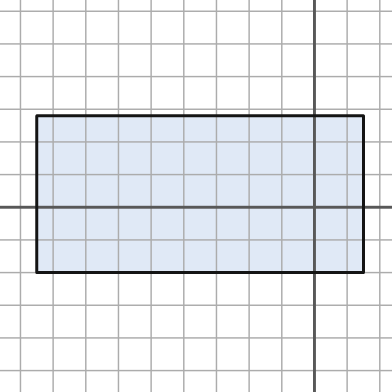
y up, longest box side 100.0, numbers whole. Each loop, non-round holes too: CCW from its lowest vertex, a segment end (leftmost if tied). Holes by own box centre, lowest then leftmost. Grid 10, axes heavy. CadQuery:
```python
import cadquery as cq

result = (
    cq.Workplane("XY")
    .moveTo(-85.0, -20.0)
    .lineTo(15.0, -20.0)
    .lineTo(15.0, 28.0)
    .lineTo(-85.0, 28.0)
    .close()
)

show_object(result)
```